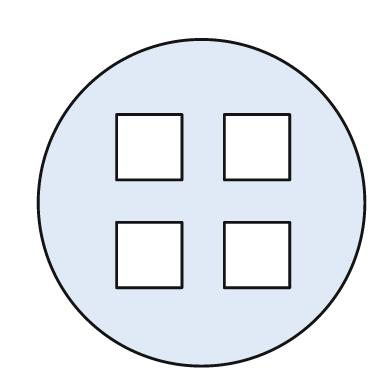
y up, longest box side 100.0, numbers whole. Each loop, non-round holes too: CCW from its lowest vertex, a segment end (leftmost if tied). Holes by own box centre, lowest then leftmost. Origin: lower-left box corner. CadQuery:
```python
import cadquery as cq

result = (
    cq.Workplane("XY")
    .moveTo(50.0, 50.0)
    .circle(50.0)
    .moveTo(24.0, 24.0)
    .lineTo(44.0, 24.0)
    .lineTo(44.0, 44.0)
    .lineTo(24.0, 44.0)
    .close()
    .moveTo(57.0, 24.0)
    .lineTo(77.0, 24.0)
    .lineTo(77.0, 44.0)
    .lineTo(57.0, 44.0)
    .close()
    .moveTo(24.0, 57.0)
    .lineTo(44.0, 57.0)
    .lineTo(44.0, 77.0)
    .lineTo(24.0, 77.0)
    .close()
    .moveTo(57.0, 57.0)
    .lineTo(77.0, 57.0)
    .lineTo(77.0, 77.0)
    .lineTo(57.0, 77.0)
    .close()
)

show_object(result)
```